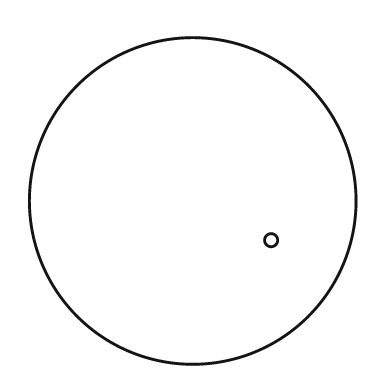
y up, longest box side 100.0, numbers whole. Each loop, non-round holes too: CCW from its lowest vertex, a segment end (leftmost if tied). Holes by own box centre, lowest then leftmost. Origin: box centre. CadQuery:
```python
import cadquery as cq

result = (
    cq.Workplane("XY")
    .moveTo(0.0, 0.0)
    .circle(50.0)
    .moveTo(24.0, -12.0)
    .circle(2.0)
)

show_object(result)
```